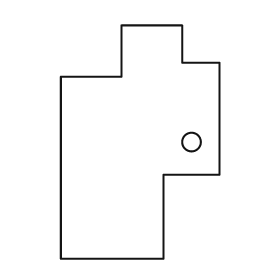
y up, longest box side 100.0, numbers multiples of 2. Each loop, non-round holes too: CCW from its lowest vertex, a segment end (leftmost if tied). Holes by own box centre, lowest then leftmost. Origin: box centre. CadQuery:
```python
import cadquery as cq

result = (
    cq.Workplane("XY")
    .moveTo(-34.0, -50.0)
    .lineTo(10.0, -50.0)
    .lineTo(10.0, -14.0)
    .lineTo(34.0, -14.0)
    .lineTo(34.0, 34.0)
    .lineTo(18.0, 34.0)
    .lineTo(18.0, 50.0)
    .lineTo(-8.0, 50.0)
    .lineTo(-8.0, 28.0)
    .lineTo(-34.0, 28.0)
    .close()
    .moveTo(22.0, 0.0)
    .circle(4.0)
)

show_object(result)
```